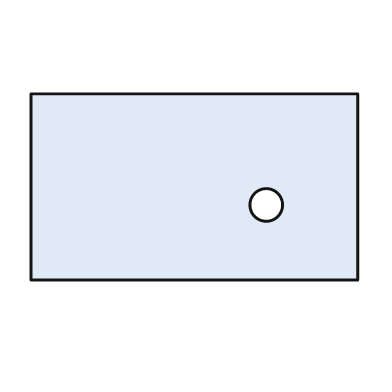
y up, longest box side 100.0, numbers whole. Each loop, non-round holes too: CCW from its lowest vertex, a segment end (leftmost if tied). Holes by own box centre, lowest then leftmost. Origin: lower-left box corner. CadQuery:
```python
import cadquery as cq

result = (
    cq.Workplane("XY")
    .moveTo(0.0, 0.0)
    .lineTo(100.0, 0.0)
    .lineTo(100.0, 57.0)
    .lineTo(0.0, 57.0)
    .close()
    .moveTo(72.0, 23.0)
    .circle(5.0)
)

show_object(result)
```